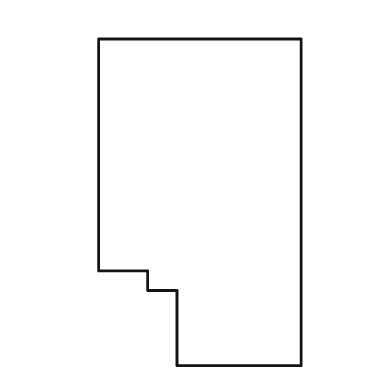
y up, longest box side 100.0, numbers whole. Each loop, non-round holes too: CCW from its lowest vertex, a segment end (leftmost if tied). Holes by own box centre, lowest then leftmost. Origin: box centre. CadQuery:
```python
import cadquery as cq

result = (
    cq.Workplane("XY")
    .moveTo(-7.0, -50.0)
    .lineTo(31.0, -50.0)
    .lineTo(31.0, 50.0)
    .lineTo(-31.0, 50.0)
    .lineTo(-31.0, -21.0)
    .lineTo(-16.0, -21.0)
    .lineTo(-16.0, -27.0)
    .lineTo(-7.0, -27.0)
    .close()
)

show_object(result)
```